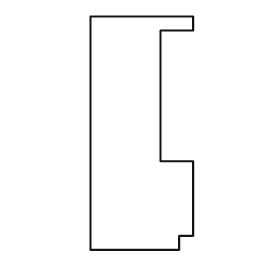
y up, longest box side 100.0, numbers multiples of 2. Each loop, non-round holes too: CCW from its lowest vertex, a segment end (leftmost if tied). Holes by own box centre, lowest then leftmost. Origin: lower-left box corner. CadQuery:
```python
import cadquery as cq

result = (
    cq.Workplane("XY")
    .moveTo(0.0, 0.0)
    .lineTo(38.0, 0.0)
    .lineTo(38.0, 6.0)
    .lineTo(44.0, 6.0)
    .lineTo(44.0, 38.0)
    .lineTo(30.0, 38.0)
    .lineTo(30.0, 94.0)
    .lineTo(44.0, 94.0)
    .lineTo(44.0, 100.0)
    .lineTo(0.0, 100.0)
    .close()
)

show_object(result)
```